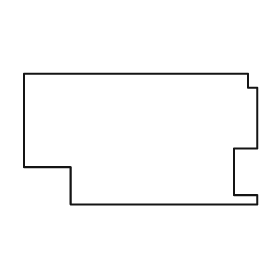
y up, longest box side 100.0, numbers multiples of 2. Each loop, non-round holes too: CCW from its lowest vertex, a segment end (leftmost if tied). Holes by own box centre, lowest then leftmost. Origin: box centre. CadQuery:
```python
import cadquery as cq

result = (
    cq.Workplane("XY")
    .moveTo(-30.0, -28.0)
    .lineTo(50.0, -28.0)
    .lineTo(50.0, -24.0)
    .lineTo(40.0, -24.0)
    .lineTo(40.0, -4.0)
    .lineTo(50.0, -4.0)
    .lineTo(50.0, 22.0)
    .lineTo(46.0, 22.0)
    .lineTo(46.0, 28.0)
    .lineTo(-50.0, 28.0)
    .lineTo(-50.0, -12.0)
    .lineTo(-30.0, -12.0)
    .close()
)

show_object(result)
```